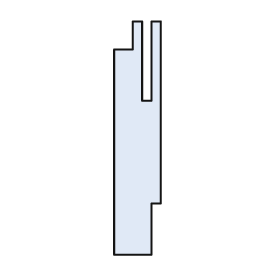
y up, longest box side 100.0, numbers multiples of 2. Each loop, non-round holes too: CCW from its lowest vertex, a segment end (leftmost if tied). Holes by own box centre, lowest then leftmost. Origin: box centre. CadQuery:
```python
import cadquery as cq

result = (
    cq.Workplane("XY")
    .moveTo(-10.0, -50.0)
    .lineTo(6.0, -50.0)
    .lineTo(6.0, -28.0)
    .lineTo(10.0, -28.0)
    .lineTo(10.0, 50.0)
    .lineTo(6.0, 50.0)
    .lineTo(6.0, 16.0)
    .lineTo(2.0, 16.0)
    .lineTo(2.0, 50.0)
    .lineTo(-2.0, 50.0)
    .lineTo(-2.0, 38.0)
    .lineTo(-10.0, 38.0)
    .close()
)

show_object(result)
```